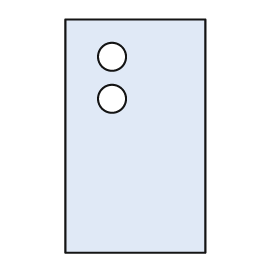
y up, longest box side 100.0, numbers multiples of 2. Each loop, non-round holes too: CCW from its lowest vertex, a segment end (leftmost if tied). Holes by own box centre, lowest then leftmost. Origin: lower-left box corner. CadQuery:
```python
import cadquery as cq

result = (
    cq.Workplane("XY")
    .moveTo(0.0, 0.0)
    .lineTo(60.0, 0.0)
    .lineTo(60.0, 100.0)
    .lineTo(0.0, 100.0)
    .close()
    .moveTo(20.0, 66.0)
    .circle(6.0)
    .moveTo(20.0, 84.0)
    .circle(6.0)
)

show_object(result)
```